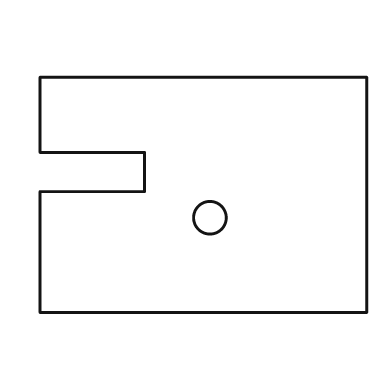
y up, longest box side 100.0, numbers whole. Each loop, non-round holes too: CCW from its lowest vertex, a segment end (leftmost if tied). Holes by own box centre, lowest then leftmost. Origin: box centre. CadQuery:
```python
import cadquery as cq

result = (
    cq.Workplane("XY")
    .moveTo(-50.0, -36.0)
    .lineTo(50.0, -36.0)
    .lineTo(50.0, 36.0)
    .lineTo(-50.0, 36.0)
    .lineTo(-50.0, 13.0)
    .lineTo(-18.0, 13.0)
    .lineTo(-18.0, 1.0)
    .lineTo(-50.0, 1.0)
    .close()
    .moveTo(2.0, -7.0)
    .circle(5.0)
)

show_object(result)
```